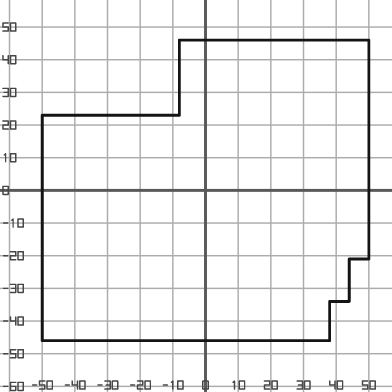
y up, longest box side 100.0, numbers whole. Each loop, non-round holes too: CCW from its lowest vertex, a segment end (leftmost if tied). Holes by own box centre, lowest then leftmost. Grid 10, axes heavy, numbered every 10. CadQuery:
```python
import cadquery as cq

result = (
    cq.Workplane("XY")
    .moveTo(-50.0, -46.0)
    .lineTo(38.0, -46.0)
    .lineTo(38.0, -34.0)
    .lineTo(44.0, -34.0)
    .lineTo(44.0, -21.0)
    .lineTo(50.0, -21.0)
    .lineTo(50.0, 46.0)
    .lineTo(-8.0, 46.0)
    .lineTo(-8.0, 23.0)
    .lineTo(-50.0, 23.0)
    .close()
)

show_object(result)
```